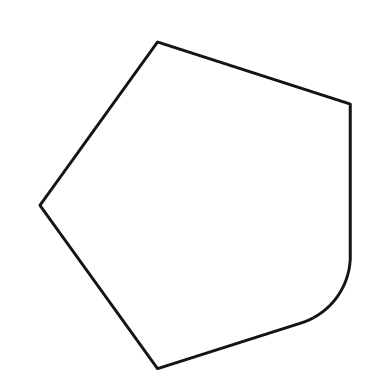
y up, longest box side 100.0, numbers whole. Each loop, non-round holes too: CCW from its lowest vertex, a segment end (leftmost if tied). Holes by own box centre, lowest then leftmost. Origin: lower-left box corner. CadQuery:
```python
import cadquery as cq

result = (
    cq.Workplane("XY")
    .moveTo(36.0, 0.0)
    .lineTo(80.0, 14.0)
    .threePointArc((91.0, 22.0), (95.0, 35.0))
    .lineTo(95.0, 81.0)
    .lineTo(36.0, 100.0)
    .lineTo(0.0, 50.0)
    .close()
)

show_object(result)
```